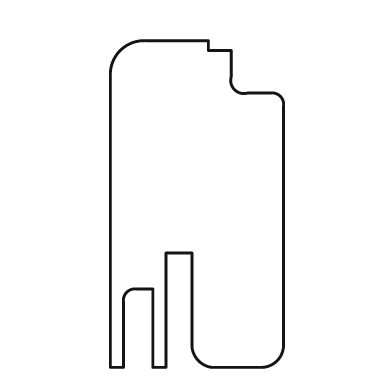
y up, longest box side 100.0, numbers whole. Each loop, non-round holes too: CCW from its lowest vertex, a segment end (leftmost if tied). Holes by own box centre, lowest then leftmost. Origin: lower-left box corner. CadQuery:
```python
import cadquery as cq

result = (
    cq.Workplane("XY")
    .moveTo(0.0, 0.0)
    .lineTo(4.0, 0.0)
    .lineTo(4.0, 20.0)
    .threePointArc((5.0, 23.0), (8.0, 24.0))
    .lineTo(13.0, 24.0)
    .lineTo(13.0, 0.0)
    .lineTo(17.0, 0.0)
    .lineTo(17.0, 35.0)
    .lineTo(25.0, 35.0)
    .lineTo(25.0, 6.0)
    .threePointArc((27.0, 2.0), (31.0, 0.0))
    .lineTo(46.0, 0.0)
    .threePointArc((51.0, 2.0), (53.0, 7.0))
    .lineTo(53.0, 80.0)
    .threePointArc((52.0, 83.0), (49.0, 84.0))
    .lineTo(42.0, 84.0)
    .threePointArc((38.0, 85.0), (37.0, 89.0))
    .lineTo(37.0, 97.0)
    .lineTo(30.0, 97.0)
    .lineTo(30.0, 100.0)
    .lineTo(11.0, 100.0)
    .threePointArc((3.0, 97.0), (0.0, 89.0))
    .close()
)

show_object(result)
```